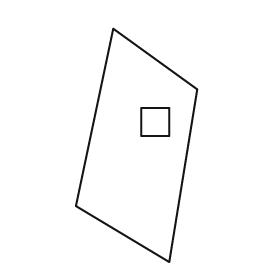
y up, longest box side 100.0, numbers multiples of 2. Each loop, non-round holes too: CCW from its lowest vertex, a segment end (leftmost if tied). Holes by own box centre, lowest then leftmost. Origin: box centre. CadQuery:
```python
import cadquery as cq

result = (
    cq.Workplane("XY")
    .moveTo(14.0, -50.0)
    .lineTo(26.0, 24.0)
    .lineTo(-10.0, 50.0)
    .lineTo(-26.0, -26.0)
    .close()
    .moveTo(2.0, 4.0)
    .lineTo(14.0, 4.0)
    .lineTo(14.0, 16.0)
    .lineTo(2.0, 16.0)
    .close()
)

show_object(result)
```